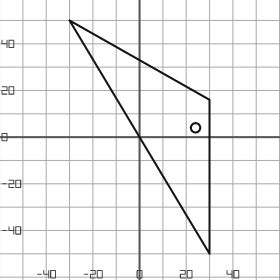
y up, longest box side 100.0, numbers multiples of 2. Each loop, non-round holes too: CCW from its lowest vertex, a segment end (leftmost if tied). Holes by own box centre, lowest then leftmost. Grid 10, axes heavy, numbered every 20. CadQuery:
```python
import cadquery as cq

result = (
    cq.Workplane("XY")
    .moveTo(30.0, -50.0)
    .lineTo(30.0, 16.0)
    .lineTo(-30.0, 50.0)
    .close()
    .moveTo(24.0, 4.0)
    .circle(2.0)
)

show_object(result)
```